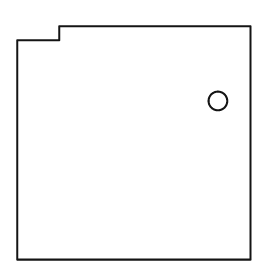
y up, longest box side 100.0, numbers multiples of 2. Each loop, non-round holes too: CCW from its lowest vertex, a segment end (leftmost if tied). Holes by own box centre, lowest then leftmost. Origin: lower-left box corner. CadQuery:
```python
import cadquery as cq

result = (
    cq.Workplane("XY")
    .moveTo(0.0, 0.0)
    .lineTo(100.0, 0.0)
    .lineTo(100.0, 100.0)
    .lineTo(18.0, 100.0)
    .lineTo(18.0, 94.0)
    .lineTo(0.0, 94.0)
    .close()
    .moveTo(86.0, 68.0)
    .circle(4.0)
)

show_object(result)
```